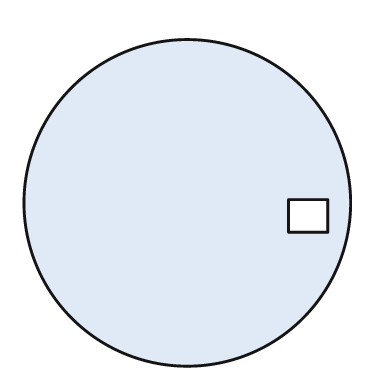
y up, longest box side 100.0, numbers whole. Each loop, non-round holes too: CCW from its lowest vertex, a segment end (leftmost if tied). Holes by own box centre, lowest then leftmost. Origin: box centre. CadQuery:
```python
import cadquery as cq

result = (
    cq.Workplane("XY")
    .moveTo(0.0, 0.0)
    .circle(50.0)
    .moveTo(31.0, -9.0)
    .lineTo(43.0, -9.0)
    .lineTo(43.0, 1.0)
    .lineTo(31.0, 1.0)
    .close()
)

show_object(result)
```